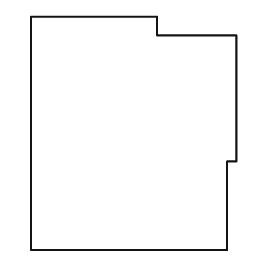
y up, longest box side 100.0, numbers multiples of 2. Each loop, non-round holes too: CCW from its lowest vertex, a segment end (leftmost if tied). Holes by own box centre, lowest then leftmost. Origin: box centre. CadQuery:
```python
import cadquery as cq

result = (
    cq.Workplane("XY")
    .moveTo(-44.0, -50.0)
    .lineTo(40.0, -50.0)
    .lineTo(40.0, -12.0)
    .lineTo(44.0, -12.0)
    .lineTo(44.0, 42.0)
    .lineTo(10.0, 42.0)
    .lineTo(10.0, 50.0)
    .lineTo(-44.0, 50.0)
    .close()
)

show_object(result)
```